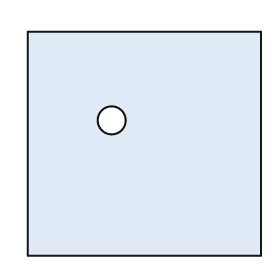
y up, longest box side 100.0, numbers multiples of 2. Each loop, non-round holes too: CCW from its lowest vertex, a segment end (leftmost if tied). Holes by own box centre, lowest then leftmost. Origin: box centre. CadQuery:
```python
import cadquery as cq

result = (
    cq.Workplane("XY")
    .moveTo(-50.0, -48.0)
    .lineTo(50.0, -48.0)
    .lineTo(50.0, 48.0)
    .lineTo(-50.0, 48.0)
    .close()
    .moveTo(-14.0, 10.0)
    .circle(6.0)
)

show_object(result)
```